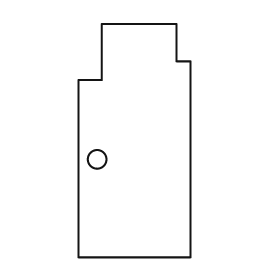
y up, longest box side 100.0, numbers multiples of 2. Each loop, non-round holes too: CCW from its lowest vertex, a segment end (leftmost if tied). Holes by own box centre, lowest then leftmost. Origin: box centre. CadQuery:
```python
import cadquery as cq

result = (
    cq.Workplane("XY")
    .moveTo(-24.0, -50.0)
    .lineTo(24.0, -50.0)
    .lineTo(24.0, 34.0)
    .lineTo(18.0, 34.0)
    .lineTo(18.0, 50.0)
    .lineTo(-14.0, 50.0)
    .lineTo(-14.0, 26.0)
    .lineTo(-24.0, 26.0)
    .close()
    .moveTo(-16.0, -8.0)
    .circle(4.0)
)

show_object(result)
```